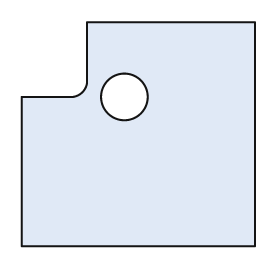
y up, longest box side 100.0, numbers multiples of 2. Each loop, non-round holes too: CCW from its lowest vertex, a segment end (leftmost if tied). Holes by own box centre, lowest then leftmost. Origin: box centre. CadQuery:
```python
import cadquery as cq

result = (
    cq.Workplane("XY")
    .moveTo(-50.0, -48.0)
    .lineTo(50.0, -48.0)
    .lineTo(50.0, 48.0)
    .lineTo(-22.0, 48.0)
    .lineTo(-22.0, 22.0)
    .threePointArc((-24.0, 18.0), (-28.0, 16.0))
    .lineTo(-50.0, 16.0)
    .close()
    .moveTo(-6.0, 16.0)
    .circle(10.0)
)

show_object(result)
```